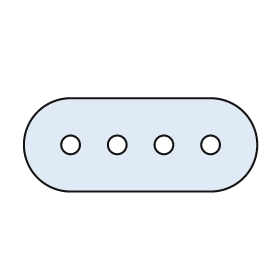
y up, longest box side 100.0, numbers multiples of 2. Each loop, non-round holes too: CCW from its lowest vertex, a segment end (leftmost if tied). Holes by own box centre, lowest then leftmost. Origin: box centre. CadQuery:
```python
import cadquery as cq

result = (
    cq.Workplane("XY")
    .moveTo(-30.0, -20.0)
    .lineTo(30.0, -20.0)
    .threePointArc((50.0, 0.0), (30.0, 20.0))
    .lineTo(-30.0, 20.0)
    .threePointArc((-50.0, 0.0), (-30.0, -20.0))
    .close()
    .moveTo(-30.0, 0.0)
    .circle(4.0)
    .moveTo(-10.0, 0.0)
    .circle(4.0)
    .moveTo(10.0, 0.0)
    .circle(4.0)
    .moveTo(30.0, 0.0)
    .circle(4.0)
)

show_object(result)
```